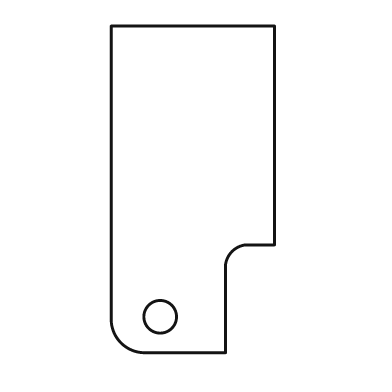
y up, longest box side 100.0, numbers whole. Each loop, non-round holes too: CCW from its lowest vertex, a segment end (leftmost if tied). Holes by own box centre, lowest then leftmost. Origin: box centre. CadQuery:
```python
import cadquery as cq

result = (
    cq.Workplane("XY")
    .moveTo(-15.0, -50.0)
    .lineTo(10.0, -50.0)
    .lineTo(10.0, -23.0)
    .threePointArc((12.0, -19.0), (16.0, -17.0))
    .lineTo(25.0, -17.0)
    .lineTo(25.0, 50.0)
    .lineTo(-25.0, 50.0)
    .lineTo(-25.0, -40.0)
    .threePointArc((-22.0, -47.0), (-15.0, -50.0))
    .close()
    .moveTo(-10.0, -39.0)
    .circle(5.0)
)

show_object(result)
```